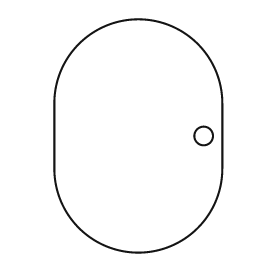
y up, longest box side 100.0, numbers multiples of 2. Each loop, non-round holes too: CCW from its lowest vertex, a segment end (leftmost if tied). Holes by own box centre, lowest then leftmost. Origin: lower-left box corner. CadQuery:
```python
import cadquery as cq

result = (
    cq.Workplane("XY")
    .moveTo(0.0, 36.0)
    .threePointArc((36.0, 0.0), (72.0, 36.0))
    .lineTo(72.0, 64.0)
    .threePointArc((36.0, 100.0), (0.0, 64.0))
    .close()
    .moveTo(64.0, 50.0)
    .circle(4.0)
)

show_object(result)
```